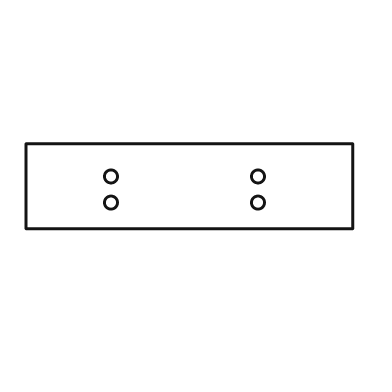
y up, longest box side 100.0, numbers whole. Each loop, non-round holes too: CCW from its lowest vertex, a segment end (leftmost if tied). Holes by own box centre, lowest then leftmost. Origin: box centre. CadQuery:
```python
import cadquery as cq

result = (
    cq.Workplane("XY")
    .moveTo(-50.0, -13.0)
    .lineTo(50.0, -13.0)
    .lineTo(50.0, 13.0)
    .lineTo(-50.0, 13.0)
    .close()
    .moveTo(-24.0, -5.0)
    .circle(2.0)
    .moveTo(21.0, -5.0)
    .circle(2.0)
    .moveTo(-24.0, 3.0)
    .circle(2.0)
    .moveTo(21.0, 3.0)
    .circle(2.0)
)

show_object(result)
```